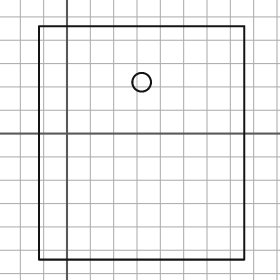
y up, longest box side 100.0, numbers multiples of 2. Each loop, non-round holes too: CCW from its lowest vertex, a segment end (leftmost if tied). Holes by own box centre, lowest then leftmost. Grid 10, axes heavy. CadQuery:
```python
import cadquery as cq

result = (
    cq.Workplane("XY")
    .moveTo(-12.0, -54.0)
    .lineTo(76.0, -54.0)
    .lineTo(76.0, 46.0)
    .lineTo(-12.0, 46.0)
    .close()
    .moveTo(32.0, 22.0)
    .circle(4.0)
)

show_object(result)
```